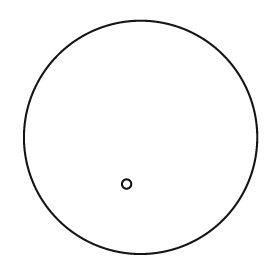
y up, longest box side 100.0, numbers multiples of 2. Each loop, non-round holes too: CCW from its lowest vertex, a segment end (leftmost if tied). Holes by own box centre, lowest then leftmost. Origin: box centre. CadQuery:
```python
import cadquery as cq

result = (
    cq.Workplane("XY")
    .moveTo(0.0, 0.0)
    .circle(50.0)
    .moveTo(-6.0, -20.0)
    .circle(2.0)
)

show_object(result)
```